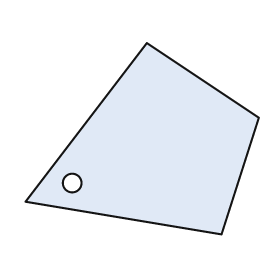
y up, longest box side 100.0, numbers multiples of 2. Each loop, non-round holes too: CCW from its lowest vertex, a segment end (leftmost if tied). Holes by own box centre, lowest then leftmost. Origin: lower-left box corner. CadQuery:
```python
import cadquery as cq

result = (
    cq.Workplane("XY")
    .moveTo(84.0, 0.0)
    .lineTo(100.0, 50.0)
    .lineTo(52.0, 82.0)
    .lineTo(0.0, 14.0)
    .close()
    .moveTo(20.0, 22.0)
    .circle(4.0)
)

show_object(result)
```